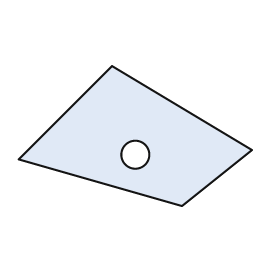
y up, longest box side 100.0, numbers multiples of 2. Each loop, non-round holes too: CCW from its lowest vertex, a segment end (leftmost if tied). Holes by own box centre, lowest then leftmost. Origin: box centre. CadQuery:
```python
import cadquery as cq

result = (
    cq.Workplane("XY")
    .moveTo(20.0, -30.0)
    .lineTo(50.0, -6.0)
    .lineTo(-10.0, 30.0)
    .lineTo(-50.0, -10.0)
    .close()
    .moveTo(0.0, -8.0)
    .circle(6.0)
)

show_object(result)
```